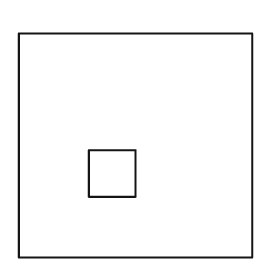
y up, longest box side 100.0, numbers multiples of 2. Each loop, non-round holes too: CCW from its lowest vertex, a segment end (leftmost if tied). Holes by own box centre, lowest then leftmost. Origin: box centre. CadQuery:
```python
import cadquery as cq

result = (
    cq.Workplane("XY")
    .moveTo(-50.0, -48.0)
    .lineTo(50.0, -48.0)
    .lineTo(50.0, 48.0)
    .lineTo(-50.0, 48.0)
    .close()
    .moveTo(-20.0, -22.0)
    .lineTo(0.0, -22.0)
    .lineTo(0.0, -2.0)
    .lineTo(-20.0, -2.0)
    .close()
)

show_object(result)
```